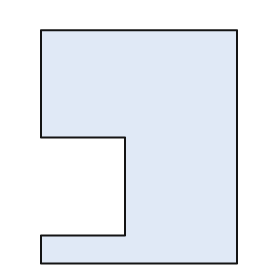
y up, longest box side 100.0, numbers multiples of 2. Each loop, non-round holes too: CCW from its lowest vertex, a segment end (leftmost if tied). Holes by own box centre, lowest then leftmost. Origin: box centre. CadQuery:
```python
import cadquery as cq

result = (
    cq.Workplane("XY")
    .moveTo(-42.0, -50.0)
    .lineTo(42.0, -50.0)
    .lineTo(42.0, 50.0)
    .lineTo(-42.0, 50.0)
    .lineTo(-42.0, 4.0)
    .lineTo(-6.0, 4.0)
    .lineTo(-6.0, -38.0)
    .lineTo(-42.0, -38.0)
    .close()
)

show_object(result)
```